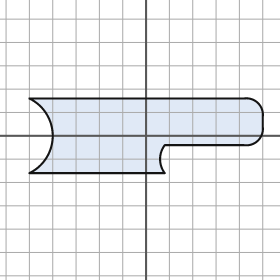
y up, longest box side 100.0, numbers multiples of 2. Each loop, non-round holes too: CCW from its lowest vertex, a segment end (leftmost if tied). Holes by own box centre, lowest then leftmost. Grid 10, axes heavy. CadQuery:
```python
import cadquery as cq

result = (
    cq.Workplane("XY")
    .moveTo(-50.0, -16.0)
    .lineTo(8.0, -16.0)
    .threePointArc((6.0, -10.0), (8.0, -4.0))
    .lineTo(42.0, -4.0)
    .threePointArc((48.0, -2.0), (50.0, 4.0))
    .lineTo(50.0, 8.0)
    .threePointArc((48.0, 14.0), (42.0, 16.0))
    .lineTo(-50.0, 16.0)
    .threePointArc((-40.0, 0.0), (-50.0, -16.0))
    .close()
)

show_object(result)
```